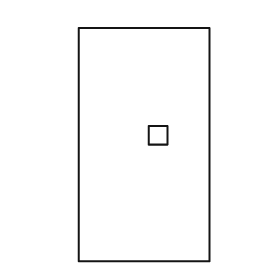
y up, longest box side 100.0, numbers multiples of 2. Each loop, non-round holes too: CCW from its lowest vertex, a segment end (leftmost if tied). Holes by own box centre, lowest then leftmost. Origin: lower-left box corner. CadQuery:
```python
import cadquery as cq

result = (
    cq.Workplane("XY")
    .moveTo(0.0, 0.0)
    .lineTo(56.0, 0.0)
    .lineTo(56.0, 100.0)
    .lineTo(0.0, 100.0)
    .close()
    .moveTo(30.0, 50.0)
    .lineTo(38.0, 50.0)
    .lineTo(38.0, 58.0)
    .lineTo(30.0, 58.0)
    .close()
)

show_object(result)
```